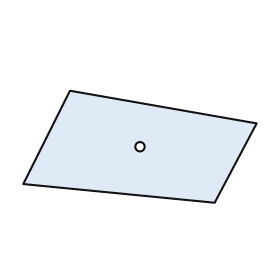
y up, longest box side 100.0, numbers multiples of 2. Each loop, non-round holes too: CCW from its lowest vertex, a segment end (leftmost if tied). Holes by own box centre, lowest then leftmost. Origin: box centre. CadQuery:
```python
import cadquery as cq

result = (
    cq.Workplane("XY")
    .moveTo(32.0, -24.0)
    .lineTo(50.0, 10.0)
    .lineTo(-30.0, 24.0)
    .lineTo(-50.0, -16.0)
    .close()
    .moveTo(0.0, 0.0)
    .circle(2.0)
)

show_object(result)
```